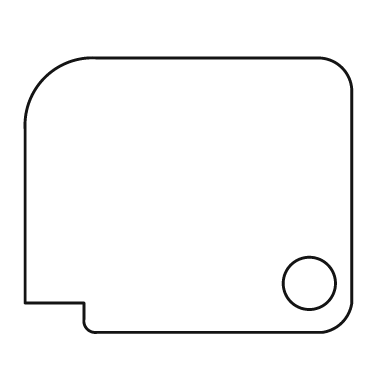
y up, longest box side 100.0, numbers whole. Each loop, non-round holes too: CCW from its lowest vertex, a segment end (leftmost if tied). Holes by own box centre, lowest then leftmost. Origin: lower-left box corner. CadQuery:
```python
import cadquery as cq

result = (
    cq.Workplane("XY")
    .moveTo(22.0, 0.0)
    .lineTo(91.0, 0.0)
    .threePointArc((97.0, 3.0), (100.0, 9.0))
    .lineTo(100.0, 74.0)
    .threePointArc((97.0, 81.0), (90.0, 84.0))
    .lineTo(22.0, 84.0)
    .threePointArc((6.0, 78.0), (0.0, 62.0))
    .lineTo(0.0, 9.0)
    .lineTo(18.0, 9.0)
    .lineTo(18.0, 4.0)
    .threePointArc((19.0, 1.0), (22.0, 0.0))
    .close()
    .moveTo(87.0, 15.0)
    .circle(8.0)
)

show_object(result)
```